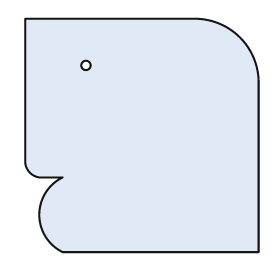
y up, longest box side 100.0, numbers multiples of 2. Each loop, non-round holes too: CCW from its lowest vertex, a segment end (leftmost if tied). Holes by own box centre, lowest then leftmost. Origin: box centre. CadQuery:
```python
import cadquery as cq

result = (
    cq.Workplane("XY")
    .moveTo(-34.0, -50.0)
    .lineTo(50.0, -50.0)
    .lineTo(50.0, 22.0)
    .threePointArc((42.0, 42.0), (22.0, 50.0))
    .lineTo(-50.0, 50.0)
    .lineTo(-50.0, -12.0)
    .threePointArc((-48.0, -16.0), (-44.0, -18.0))
    .lineTo(-34.0, -18.0)
    .threePointArc((-44.0, -34.0), (-34.0, -50.0))
    .close()
    .moveTo(-24.0, 30.0)
    .circle(2.0)
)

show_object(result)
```